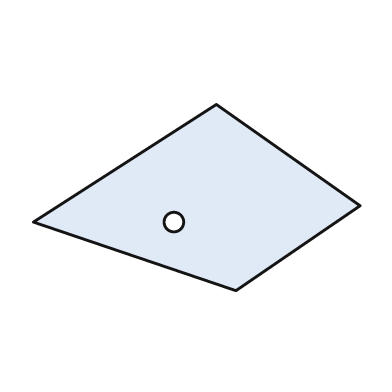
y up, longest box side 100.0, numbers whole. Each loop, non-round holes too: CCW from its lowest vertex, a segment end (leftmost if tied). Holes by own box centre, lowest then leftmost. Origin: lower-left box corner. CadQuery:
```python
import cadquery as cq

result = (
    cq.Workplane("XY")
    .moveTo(62.0, 0.0)
    .lineTo(100.0, 26.0)
    .lineTo(56.0, 57.0)
    .lineTo(0.0, 21.0)
    .close()
    .moveTo(43.0, 21.0)
    .circle(3.0)
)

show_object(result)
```